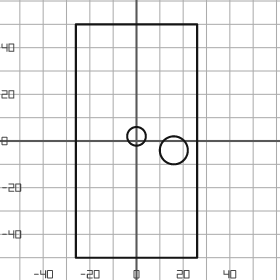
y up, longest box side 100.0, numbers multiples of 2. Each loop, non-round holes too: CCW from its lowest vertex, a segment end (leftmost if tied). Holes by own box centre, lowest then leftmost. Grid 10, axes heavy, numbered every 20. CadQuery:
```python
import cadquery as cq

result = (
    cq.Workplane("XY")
    .moveTo(-26.0, -50.0)
    .lineTo(26.0, -50.0)
    .lineTo(26.0, 50.0)
    .lineTo(-26.0, 50.0)
    .close()
    .moveTo(16.0, -4.0)
    .circle(6.0)
    .moveTo(0.0, 2.0)
    .circle(4.0)
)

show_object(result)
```